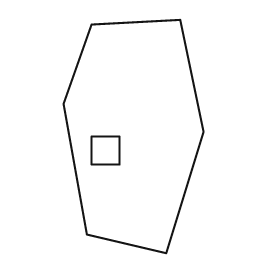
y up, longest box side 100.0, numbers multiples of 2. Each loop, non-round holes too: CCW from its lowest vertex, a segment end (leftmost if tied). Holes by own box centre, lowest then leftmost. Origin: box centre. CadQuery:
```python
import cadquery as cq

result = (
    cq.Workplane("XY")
    .moveTo(14.0, -50.0)
    .lineTo(30.0, 2.0)
    .lineTo(20.0, 50.0)
    .lineTo(-18.0, 48.0)
    .lineTo(-30.0, 14.0)
    .lineTo(-20.0, -42.0)
    .close()
    .moveTo(-18.0, -12.0)
    .lineTo(-6.0, -12.0)
    .lineTo(-6.0, 0.0)
    .lineTo(-18.0, 0.0)
    .close()
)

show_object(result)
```